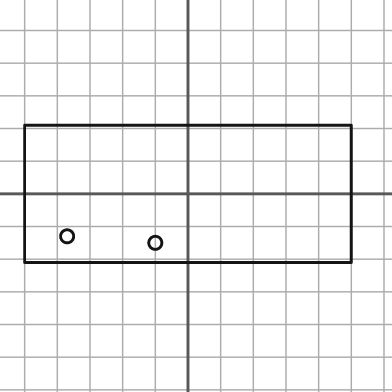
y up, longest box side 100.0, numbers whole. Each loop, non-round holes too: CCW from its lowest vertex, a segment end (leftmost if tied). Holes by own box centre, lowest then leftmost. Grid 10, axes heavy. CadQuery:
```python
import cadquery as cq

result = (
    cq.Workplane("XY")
    .moveTo(-50.0, -21.0)
    .lineTo(50.0, -21.0)
    .lineTo(50.0, 21.0)
    .lineTo(-50.0, 21.0)
    .close()
    .moveTo(-10.0, -15.0)
    .circle(2.0)
    .moveTo(-37.0, -13.0)
    .circle(2.0)
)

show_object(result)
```